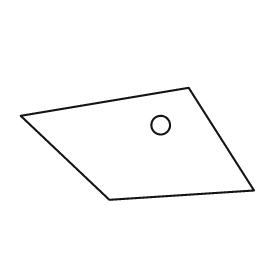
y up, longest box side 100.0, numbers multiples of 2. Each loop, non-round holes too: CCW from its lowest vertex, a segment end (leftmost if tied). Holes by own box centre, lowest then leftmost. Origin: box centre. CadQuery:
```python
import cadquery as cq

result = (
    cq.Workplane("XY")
    .moveTo(-12.0, -24.0)
    .lineTo(50.0, -20.0)
    .lineTo(22.0, 24.0)
    .lineTo(-50.0, 12.0)
    .close()
    .moveTo(10.0, 8.0)
    .circle(4.0)
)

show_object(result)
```